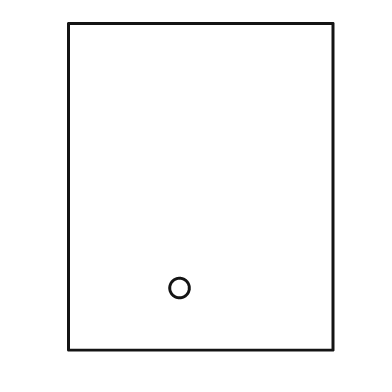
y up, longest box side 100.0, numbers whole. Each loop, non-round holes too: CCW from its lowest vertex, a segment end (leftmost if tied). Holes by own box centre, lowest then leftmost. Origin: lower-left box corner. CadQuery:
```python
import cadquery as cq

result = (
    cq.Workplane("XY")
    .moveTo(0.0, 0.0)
    .lineTo(81.0, 0.0)
    .lineTo(81.0, 100.0)
    .lineTo(0.0, 100.0)
    .close()
    .moveTo(34.0, 19.0)
    .circle(3.0)
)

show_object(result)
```